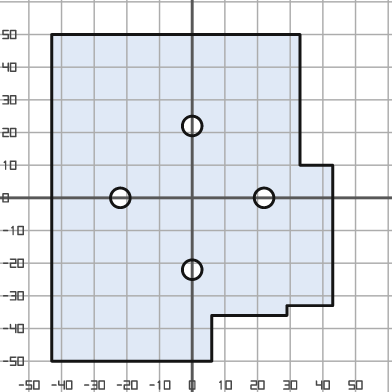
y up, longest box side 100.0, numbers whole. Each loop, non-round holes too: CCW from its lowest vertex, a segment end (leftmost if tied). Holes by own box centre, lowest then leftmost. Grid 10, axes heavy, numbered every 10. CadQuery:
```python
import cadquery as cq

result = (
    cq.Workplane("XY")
    .moveTo(-43.0, -50.0)
    .lineTo(6.0, -50.0)
    .lineTo(6.0, -36.0)
    .lineTo(29.0, -36.0)
    .lineTo(29.0, -33.0)
    .lineTo(43.0, -33.0)
    .lineTo(43.0, 10.0)
    .lineTo(33.0, 10.0)
    .lineTo(33.0, 50.0)
    .lineTo(-43.0, 50.0)
    .close()
    .moveTo(0.0, -22.0)
    .circle(3.0)
    .moveTo(-22.0, 0.0)
    .circle(3.0)
    .moveTo(22.0, 0.0)
    .circle(3.0)
    .moveTo(0.0, 22.0)
    .circle(3.0)
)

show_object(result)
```